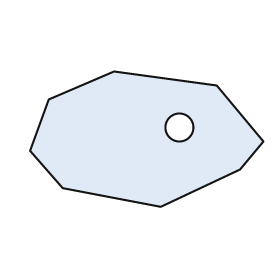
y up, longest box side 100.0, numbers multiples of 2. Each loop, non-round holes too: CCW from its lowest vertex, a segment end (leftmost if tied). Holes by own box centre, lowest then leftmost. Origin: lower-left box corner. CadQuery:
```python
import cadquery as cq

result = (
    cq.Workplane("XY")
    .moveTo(56.0, 0.0)
    .lineTo(90.0, 16.0)
    .lineTo(100.0, 28.0)
    .lineTo(80.0, 52.0)
    .lineTo(36.0, 58.0)
    .lineTo(8.0, 46.0)
    .lineTo(0.0, 24.0)
    .lineTo(14.0, 8.0)
    .close()
    .moveTo(64.0, 34.0)
    .circle(6.0)
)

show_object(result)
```